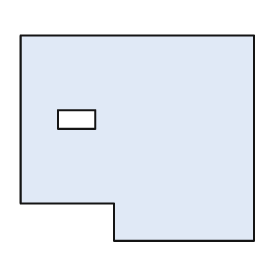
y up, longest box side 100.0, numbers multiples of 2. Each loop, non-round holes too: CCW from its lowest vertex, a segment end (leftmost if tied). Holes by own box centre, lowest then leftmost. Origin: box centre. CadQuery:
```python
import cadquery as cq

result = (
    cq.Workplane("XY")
    .moveTo(-10.0, -44.0)
    .lineTo(50.0, -44.0)
    .lineTo(50.0, 44.0)
    .lineTo(-50.0, 44.0)
    .lineTo(-50.0, -28.0)
    .lineTo(-10.0, -28.0)
    .close()
    .moveTo(-34.0, 4.0)
    .lineTo(-18.0, 4.0)
    .lineTo(-18.0, 12.0)
    .lineTo(-34.0, 12.0)
    .close()
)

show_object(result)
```